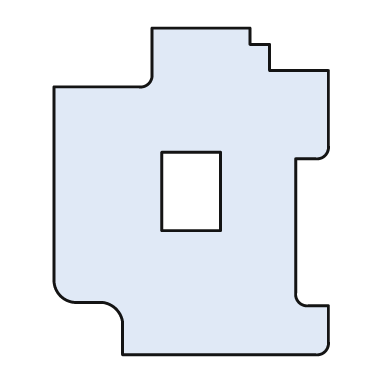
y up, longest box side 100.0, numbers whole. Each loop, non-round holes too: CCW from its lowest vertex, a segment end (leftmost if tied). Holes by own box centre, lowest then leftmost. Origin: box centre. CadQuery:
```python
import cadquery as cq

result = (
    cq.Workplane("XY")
    .moveTo(-21.0, -50.0)
    .lineTo(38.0, -50.0)
    .threePointArc((41.0, -49.0), (42.0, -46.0))
    .lineTo(42.0, -35.0)
    .lineTo(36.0, -35.0)
    .threePointArc((33.0, -34.0), (32.0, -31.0))
    .lineTo(32.0, 10.0)
    .lineTo(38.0, 10.0)
    .threePointArc((41.0, 11.0), (42.0, 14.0))
    .lineTo(42.0, 37.0)
    .lineTo(24.0, 37.0)
    .lineTo(24.0, 45.0)
    .lineTo(18.0, 45.0)
    .lineTo(18.0, 50.0)
    .lineTo(-12.0, 50.0)
    .lineTo(-12.0, 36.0)
    .threePointArc((-13.0, 33.0), (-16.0, 32.0))
    .lineTo(-42.0, 32.0)
    .lineTo(-42.0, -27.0)
    .threePointArc((-40.0, -32.0), (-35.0, -34.0))
    .lineTo(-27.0, -34.0)
    .threePointArc((-23.0, -36.0), (-21.0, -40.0))
    .close()
    .moveTo(-9.0, -12.0)
    .lineTo(9.0, -12.0)
    .lineTo(9.0, 12.0)
    .lineTo(-9.0, 12.0)
    .close()
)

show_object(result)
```